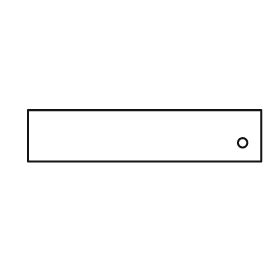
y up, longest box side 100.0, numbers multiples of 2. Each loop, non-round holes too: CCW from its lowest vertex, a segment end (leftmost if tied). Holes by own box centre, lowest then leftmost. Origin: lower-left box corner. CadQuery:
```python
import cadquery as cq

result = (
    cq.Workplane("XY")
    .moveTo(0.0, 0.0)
    .lineTo(100.0, 0.0)
    .lineTo(100.0, 22.0)
    .lineTo(0.0, 22.0)
    .close()
    .moveTo(92.0, 8.0)
    .circle(2.0)
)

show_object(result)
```